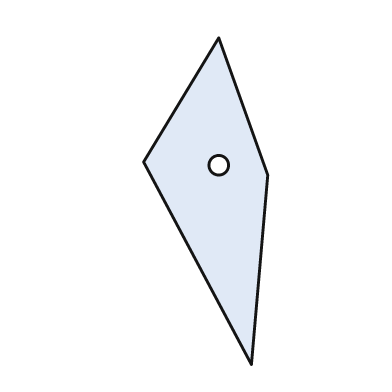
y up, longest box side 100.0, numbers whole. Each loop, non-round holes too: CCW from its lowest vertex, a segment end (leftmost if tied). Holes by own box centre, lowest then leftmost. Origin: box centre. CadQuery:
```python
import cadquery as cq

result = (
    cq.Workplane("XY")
    .moveTo(14.0, -50.0)
    .lineTo(19.0, 8.0)
    .lineTo(4.0, 50.0)
    .lineTo(-19.0, 12.0)
    .close()
    .moveTo(4.0, 11.0)
    .circle(3.0)
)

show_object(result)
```